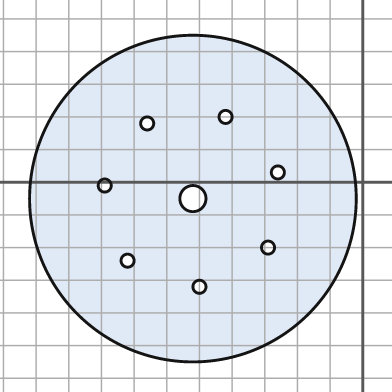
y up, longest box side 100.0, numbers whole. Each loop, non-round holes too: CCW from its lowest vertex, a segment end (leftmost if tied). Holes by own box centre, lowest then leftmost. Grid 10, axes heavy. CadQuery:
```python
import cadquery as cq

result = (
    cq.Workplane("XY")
    .moveTo(-52.0, -5.0)
    .circle(50.0)
    .moveTo(-50.0, -32.0)
    .circle(2.0)
    .moveTo(-72.0, -24.0)
    .circle(2.0)
    .moveTo(-29.0, -20.0)
    .circle(2.0)
    .moveTo(-52.0, -5.0)
    .circle(4.0)
    .moveTo(-79.0, -1.0)
    .circle(2.0)
    .moveTo(-26.0, 3.0)
    .circle(2.0)
    .moveTo(-66.0, 18.0)
    .circle(2.0)
    .moveTo(-42.0, 20.0)
    .circle(2.0)
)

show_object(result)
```